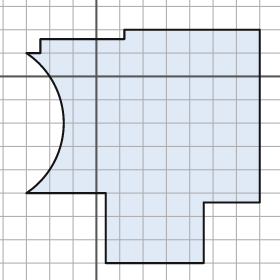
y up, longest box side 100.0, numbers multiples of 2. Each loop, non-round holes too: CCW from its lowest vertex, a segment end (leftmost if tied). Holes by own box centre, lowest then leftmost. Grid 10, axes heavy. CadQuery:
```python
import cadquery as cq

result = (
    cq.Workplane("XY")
    .moveTo(4.0, -80.0)
    .lineTo(46.0, -80.0)
    .lineTo(46.0, -54.0)
    .lineTo(70.0, -54.0)
    .lineTo(70.0, 20.0)
    .lineTo(12.0, 20.0)
    .lineTo(12.0, 16.0)
    .lineTo(-24.0, 16.0)
    .lineTo(-24.0, 10.0)
    .lineTo(-30.0, 10.0)
    .threePointArc((-14.0, -20.0), (-30.0, -50.0))
    .lineTo(4.0, -50.0)
    .close()
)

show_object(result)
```